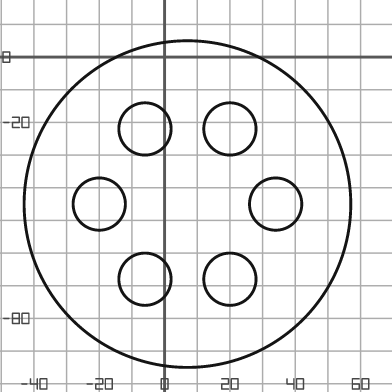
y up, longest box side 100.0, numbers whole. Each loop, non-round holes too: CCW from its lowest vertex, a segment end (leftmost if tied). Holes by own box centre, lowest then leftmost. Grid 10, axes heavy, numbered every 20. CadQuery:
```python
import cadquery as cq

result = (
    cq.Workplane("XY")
    .moveTo(7.0, -45.0)
    .circle(50.0)
    .moveTo(-6.0, -68.0)
    .circle(8.0)
    .moveTo(20.0, -68.0)
    .circle(8.0)
    .moveTo(-20.0, -45.0)
    .circle(8.0)
    .moveTo(34.0, -45.0)
    .circle(8.0)
    .moveTo(-6.0, -22.0)
    .circle(8.0)
    .moveTo(20.0, -22.0)
    .circle(8.0)
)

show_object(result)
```